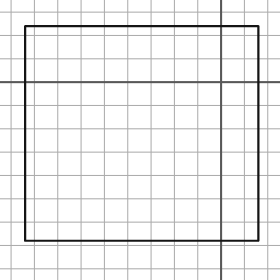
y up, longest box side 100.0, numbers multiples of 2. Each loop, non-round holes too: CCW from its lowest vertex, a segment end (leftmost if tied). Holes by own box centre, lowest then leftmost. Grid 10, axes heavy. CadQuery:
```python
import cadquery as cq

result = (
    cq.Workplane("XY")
    .moveTo(-84.0, -68.0)
    .lineTo(16.0, -68.0)
    .lineTo(16.0, 24.0)
    .lineTo(-84.0, 24.0)
    .close()
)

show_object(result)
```